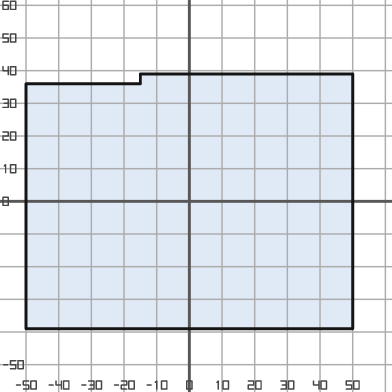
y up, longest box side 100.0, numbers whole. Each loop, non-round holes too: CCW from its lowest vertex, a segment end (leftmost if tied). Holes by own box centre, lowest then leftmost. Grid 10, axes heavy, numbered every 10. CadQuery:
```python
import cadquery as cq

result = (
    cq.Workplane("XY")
    .moveTo(-50.0, -39.0)
    .lineTo(50.0, -39.0)
    .lineTo(50.0, 39.0)
    .lineTo(-15.0, 39.0)
    .lineTo(-15.0, 36.0)
    .lineTo(-50.0, 36.0)
    .close()
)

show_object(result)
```